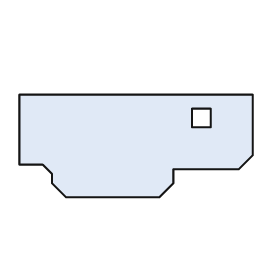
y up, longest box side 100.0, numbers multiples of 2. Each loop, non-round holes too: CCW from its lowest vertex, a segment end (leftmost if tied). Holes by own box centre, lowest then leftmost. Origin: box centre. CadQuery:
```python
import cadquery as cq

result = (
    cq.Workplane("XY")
    .moveTo(-30.0, -22.0)
    .lineTo(10.0, -22.0)
    .lineTo(16.0, -16.0)
    .lineTo(16.0, -10.0)
    .lineTo(44.0, -10.0)
    .lineTo(50.0, -4.0)
    .lineTo(50.0, 22.0)
    .lineTo(-50.0, 22.0)
    .lineTo(-50.0, -8.0)
    .lineTo(-40.0, -8.0)
    .lineTo(-36.0, -12.0)
    .lineTo(-36.0, -16.0)
    .close()
    .moveTo(24.0, 8.0)
    .lineTo(32.0, 8.0)
    .lineTo(32.0, 16.0)
    .lineTo(24.0, 16.0)
    .close()
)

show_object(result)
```